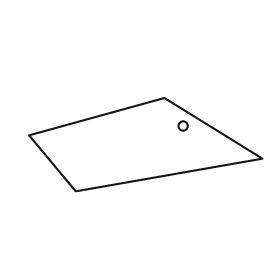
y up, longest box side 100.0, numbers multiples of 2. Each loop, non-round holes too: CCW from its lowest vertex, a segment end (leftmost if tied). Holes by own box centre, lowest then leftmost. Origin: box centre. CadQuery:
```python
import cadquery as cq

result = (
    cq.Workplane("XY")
    .moveTo(-30.0, -20.0)
    .lineTo(50.0, -6.0)
    .lineTo(8.0, 20.0)
    .lineTo(-50.0, 4.0)
    .close()
    .moveTo(16.0, 8.0)
    .circle(2.0)
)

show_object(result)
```